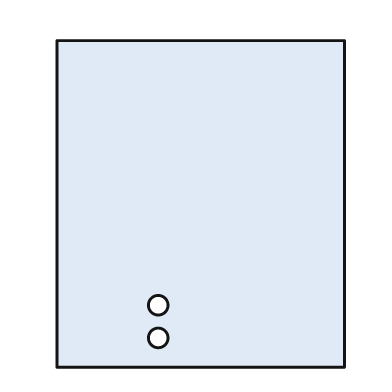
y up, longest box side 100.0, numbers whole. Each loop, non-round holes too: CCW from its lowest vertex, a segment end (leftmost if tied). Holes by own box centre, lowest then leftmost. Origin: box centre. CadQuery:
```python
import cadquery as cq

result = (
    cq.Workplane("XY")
    .moveTo(-44.0, -50.0)
    .lineTo(44.0, -50.0)
    .lineTo(44.0, 50.0)
    .lineTo(-44.0, 50.0)
    .close()
    .moveTo(-13.0, -41.0)
    .circle(3.0)
    .moveTo(-13.0, -31.0)
    .circle(3.0)
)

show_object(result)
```